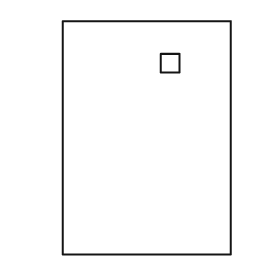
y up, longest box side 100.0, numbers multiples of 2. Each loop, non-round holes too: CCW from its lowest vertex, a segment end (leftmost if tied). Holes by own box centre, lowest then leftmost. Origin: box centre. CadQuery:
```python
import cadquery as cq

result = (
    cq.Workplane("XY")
    .moveTo(-36.0, -50.0)
    .lineTo(36.0, -50.0)
    .lineTo(36.0, 50.0)
    .lineTo(-36.0, 50.0)
    .close()
    .moveTo(6.0, 28.0)
    .lineTo(14.0, 28.0)
    .lineTo(14.0, 36.0)
    .lineTo(6.0, 36.0)
    .close()
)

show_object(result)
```